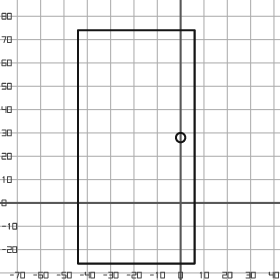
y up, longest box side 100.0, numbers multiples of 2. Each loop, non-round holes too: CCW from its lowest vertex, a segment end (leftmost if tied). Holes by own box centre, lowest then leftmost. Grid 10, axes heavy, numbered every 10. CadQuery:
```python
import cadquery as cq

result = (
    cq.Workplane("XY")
    .moveTo(-44.0, -26.0)
    .lineTo(6.0, -26.0)
    .lineTo(6.0, 74.0)
    .lineTo(-44.0, 74.0)
    .close()
    .moveTo(0.0, 28.0)
    .circle(2.0)
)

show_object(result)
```